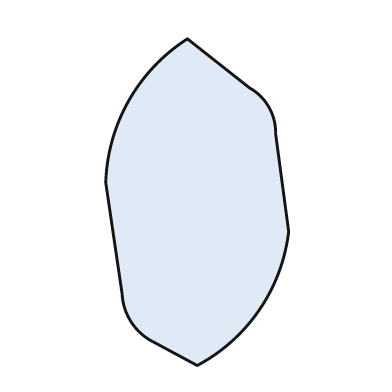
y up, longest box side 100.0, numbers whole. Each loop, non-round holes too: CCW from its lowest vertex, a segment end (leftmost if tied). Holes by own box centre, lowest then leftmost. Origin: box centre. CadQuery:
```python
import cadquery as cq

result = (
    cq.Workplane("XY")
    .moveTo(0.0, -50.0)
    .threePointArc((19.0, -33.0), (28.0, -9.0))
    .lineTo(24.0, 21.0)
    .threePointArc((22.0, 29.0), (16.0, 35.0))
    .lineTo(-3.0, 50.0)
    .threePointArc((-21.0, 31.0), (-28.0, 6.0))
    .lineTo(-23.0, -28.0)
    .threePointArc((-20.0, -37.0), (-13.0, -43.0))
    .close()
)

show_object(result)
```